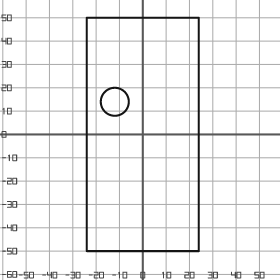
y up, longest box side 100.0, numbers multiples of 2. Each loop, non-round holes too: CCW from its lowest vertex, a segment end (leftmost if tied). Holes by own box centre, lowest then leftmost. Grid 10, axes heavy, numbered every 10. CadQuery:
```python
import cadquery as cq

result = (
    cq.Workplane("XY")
    .moveTo(-24.0, -50.0)
    .lineTo(24.0, -50.0)
    .lineTo(24.0, 50.0)
    .lineTo(-24.0, 50.0)
    .close()
    .moveTo(-12.0, 14.0)
    .circle(6.0)
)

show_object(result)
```